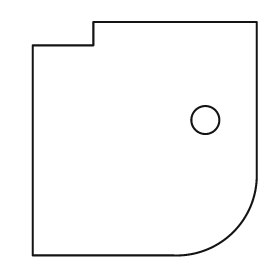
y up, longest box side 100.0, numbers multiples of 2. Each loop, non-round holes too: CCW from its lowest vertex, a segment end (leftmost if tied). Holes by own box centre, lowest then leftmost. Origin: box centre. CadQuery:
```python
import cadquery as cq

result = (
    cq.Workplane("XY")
    .moveTo(-48.0, -50.0)
    .lineTo(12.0, -50.0)
    .threePointArc((38.0, -40.0), (48.0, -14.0))
    .lineTo(48.0, 50.0)
    .lineTo(-22.0, 50.0)
    .lineTo(-22.0, 40.0)
    .lineTo(-48.0, 40.0)
    .close()
    .moveTo(26.0, 8.0)
    .circle(6.0)
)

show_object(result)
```